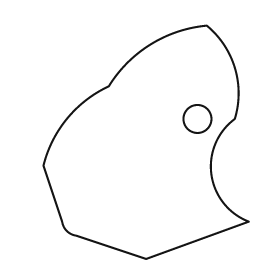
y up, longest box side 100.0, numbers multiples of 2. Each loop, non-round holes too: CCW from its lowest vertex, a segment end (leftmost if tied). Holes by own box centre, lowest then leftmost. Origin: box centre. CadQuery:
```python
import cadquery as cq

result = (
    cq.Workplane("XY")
    .moveTo(0.0, -50.0)
    .lineTo(44.0, -34.0)
    .threePointArc((28.0, -14.0), (38.0, 10.0))
    .threePointArc((38.0, 32.0), (26.0, 50.0))
    .threePointArc((2.0, 42.0), (-16.0, 24.0))
    .threePointArc((-34.0, 10.0), (-44.0, -10.0))
    .lineTo(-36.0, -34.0)
    .threePointArc((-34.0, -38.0), (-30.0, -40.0))
    .close()
    .moveTo(22.0, 10.0)
    .circle(6.0)
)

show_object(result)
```